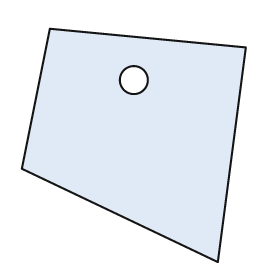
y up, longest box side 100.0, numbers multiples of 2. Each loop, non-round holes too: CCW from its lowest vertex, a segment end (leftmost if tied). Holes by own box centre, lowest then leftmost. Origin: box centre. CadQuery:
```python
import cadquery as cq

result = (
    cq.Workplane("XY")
    .moveTo(36.0, -50.0)
    .lineTo(48.0, 42.0)
    .lineTo(-36.0, 50.0)
    .lineTo(-48.0, -10.0)
    .close()
    .moveTo(0.0, 28.0)
    .circle(6.0)
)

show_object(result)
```